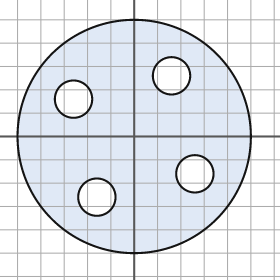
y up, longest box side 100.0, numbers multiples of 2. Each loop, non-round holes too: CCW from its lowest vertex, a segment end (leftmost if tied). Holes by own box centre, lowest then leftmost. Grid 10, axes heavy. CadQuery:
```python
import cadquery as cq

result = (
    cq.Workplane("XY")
    .moveTo(0.0, 0.0)
    .circle(50.0)
    .moveTo(-16.0, -26.0)
    .circle(8.0)
    .moveTo(26.0, -16.0)
    .circle(8.0)
    .moveTo(-26.0, 16.0)
    .circle(8.0)
    .moveTo(16.0, 26.0)
    .circle(8.0)
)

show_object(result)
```